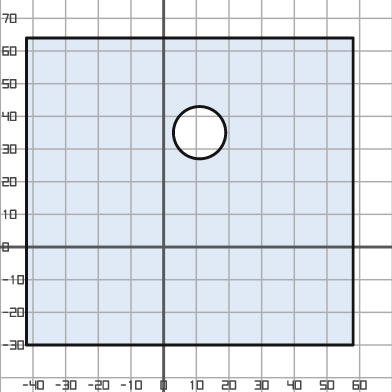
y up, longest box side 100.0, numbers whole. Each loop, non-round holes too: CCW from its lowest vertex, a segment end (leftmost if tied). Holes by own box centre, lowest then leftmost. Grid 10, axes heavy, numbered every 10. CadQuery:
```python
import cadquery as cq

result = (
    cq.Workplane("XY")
    .moveTo(-42.0, -30.0)
    .lineTo(58.0, -30.0)
    .lineTo(58.0, 64.0)
    .lineTo(-42.0, 64.0)
    .close()
    .moveTo(11.0, 35.0)
    .circle(8.0)
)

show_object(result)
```